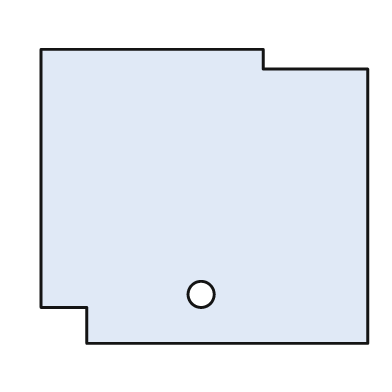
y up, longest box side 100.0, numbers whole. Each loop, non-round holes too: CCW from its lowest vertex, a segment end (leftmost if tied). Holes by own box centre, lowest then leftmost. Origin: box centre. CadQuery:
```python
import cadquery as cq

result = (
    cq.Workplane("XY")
    .moveTo(-36.0, -45.0)
    .lineTo(50.0, -45.0)
    .lineTo(50.0, 39.0)
    .lineTo(18.0, 39.0)
    .lineTo(18.0, 45.0)
    .lineTo(-50.0, 45.0)
    .lineTo(-50.0, -34.0)
    .lineTo(-36.0, -34.0)
    .close()
    .moveTo(-1.0, -30.0)
    .circle(4.0)
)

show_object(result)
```